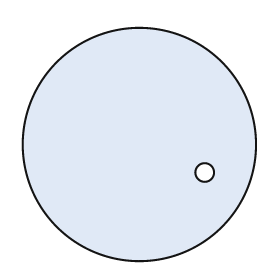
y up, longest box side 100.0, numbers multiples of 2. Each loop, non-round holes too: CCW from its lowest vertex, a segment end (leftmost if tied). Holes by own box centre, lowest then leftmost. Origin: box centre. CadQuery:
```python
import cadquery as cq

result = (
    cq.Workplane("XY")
    .moveTo(0.0, 0.0)
    .circle(50.0)
    .moveTo(28.0, -12.0)
    .circle(4.0)
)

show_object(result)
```